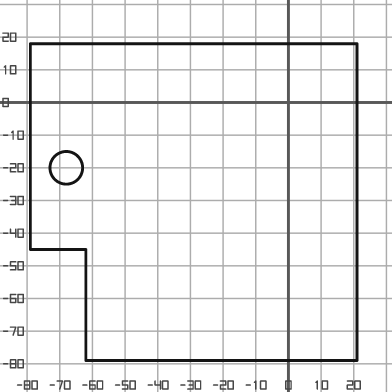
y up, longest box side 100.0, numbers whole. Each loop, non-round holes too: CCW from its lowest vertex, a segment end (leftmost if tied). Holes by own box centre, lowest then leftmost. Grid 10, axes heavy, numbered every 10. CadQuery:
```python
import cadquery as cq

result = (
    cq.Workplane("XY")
    .moveTo(-62.0, -79.0)
    .lineTo(21.0, -79.0)
    .lineTo(21.0, 18.0)
    .lineTo(-79.0, 18.0)
    .lineTo(-79.0, -45.0)
    .lineTo(-62.0, -45.0)
    .close()
    .moveTo(-68.0, -20.0)
    .circle(5.0)
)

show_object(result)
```